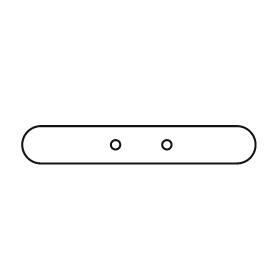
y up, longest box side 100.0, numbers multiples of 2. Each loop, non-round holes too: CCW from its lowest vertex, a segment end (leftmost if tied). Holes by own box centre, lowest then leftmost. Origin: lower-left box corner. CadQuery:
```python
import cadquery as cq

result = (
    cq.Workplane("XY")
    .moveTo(8.0, 0.0)
    .lineTo(92.0, 0.0)
    .threePointArc((100.0, 8.0), (92.0, 16.0))
    .lineTo(8.0, 16.0)
    .threePointArc((0.0, 8.0), (8.0, 0.0))
    .close()
    .moveTo(40.0, 8.0)
    .circle(2.0)
    .moveTo(62.0, 8.0)
    .circle(2.0)
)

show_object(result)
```